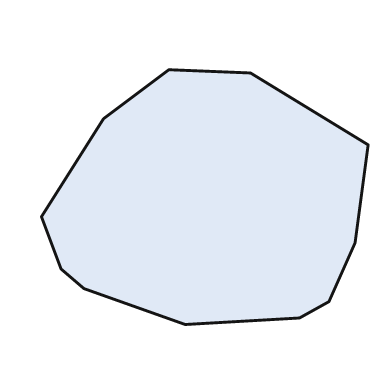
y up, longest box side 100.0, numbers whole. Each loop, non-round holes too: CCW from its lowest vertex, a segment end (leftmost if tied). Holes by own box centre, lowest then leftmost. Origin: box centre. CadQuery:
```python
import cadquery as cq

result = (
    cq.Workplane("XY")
    .moveTo(-6.0, -39.0)
    .lineTo(29.0, -37.0)
    .lineTo(38.0, -32.0)
    .lineTo(46.0, -14.0)
    .lineTo(50.0, 16.0)
    .lineTo(14.0, 38.0)
    .lineTo(-11.0, 39.0)
    .lineTo(-31.0, 24.0)
    .lineTo(-50.0, -6.0)
    .lineTo(-44.0, -22.0)
    .lineTo(-37.0, -28.0)
    .close()
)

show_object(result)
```